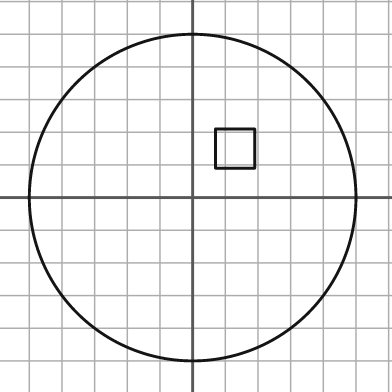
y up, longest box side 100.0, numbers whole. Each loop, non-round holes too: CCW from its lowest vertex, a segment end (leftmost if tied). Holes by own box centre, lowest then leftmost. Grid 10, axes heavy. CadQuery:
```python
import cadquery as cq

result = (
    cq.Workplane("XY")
    .moveTo(0.0, 0.0)
    .circle(50.0)
    .moveTo(7.0, 9.0)
    .lineTo(19.0, 9.0)
    .lineTo(19.0, 21.0)
    .lineTo(7.0, 21.0)
    .close()
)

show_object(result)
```